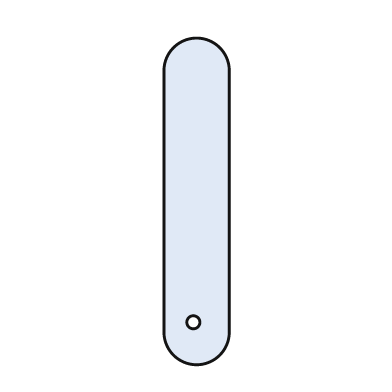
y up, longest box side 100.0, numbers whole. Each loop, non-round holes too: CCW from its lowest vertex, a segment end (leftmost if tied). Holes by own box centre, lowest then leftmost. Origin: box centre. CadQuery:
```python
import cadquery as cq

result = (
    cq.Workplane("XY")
    .moveTo(-10.0, -40.0)
    .threePointArc((0.0, -50.0), (10.0, -40.0))
    .lineTo(10.0, 40.0)
    .threePointArc((0.0, 50.0), (-10.0, 40.0))
    .close()
    .moveTo(-1.0, -37.0)
    .circle(2.0)
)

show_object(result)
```